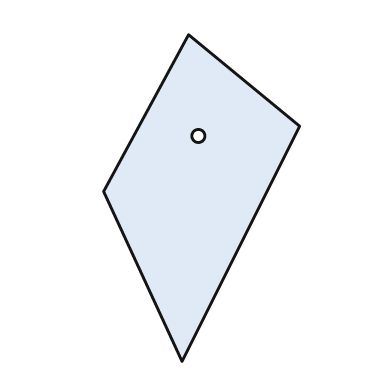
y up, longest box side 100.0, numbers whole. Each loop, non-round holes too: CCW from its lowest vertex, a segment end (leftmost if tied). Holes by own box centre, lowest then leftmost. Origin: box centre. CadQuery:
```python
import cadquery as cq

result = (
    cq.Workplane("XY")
    .moveTo(-6.0, -50.0)
    .lineTo(30.0, 22.0)
    .lineTo(-4.0, 50.0)
    .lineTo(-30.0, 2.0)
    .close()
    .moveTo(-1.0, 19.0)
    .circle(2.0)
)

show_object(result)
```